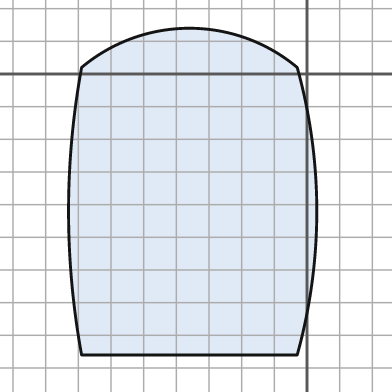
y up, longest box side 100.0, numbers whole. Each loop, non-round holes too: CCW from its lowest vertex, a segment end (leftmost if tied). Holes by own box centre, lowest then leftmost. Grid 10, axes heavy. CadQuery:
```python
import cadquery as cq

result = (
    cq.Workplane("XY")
    .moveTo(-69.0, -86.0)
    .lineTo(-3.0, -86.0)
    .threePointArc((3.0, -42.0), (-3.0, 2.0))
    .threePointArc((-36.0, 14.0), (-69.0, 2.0))
    .threePointArc((-73.0, -42.0), (-69.0, -86.0))
    .close()
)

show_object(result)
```